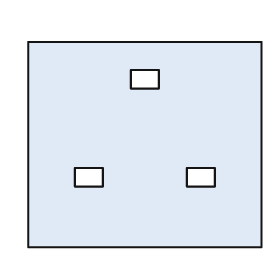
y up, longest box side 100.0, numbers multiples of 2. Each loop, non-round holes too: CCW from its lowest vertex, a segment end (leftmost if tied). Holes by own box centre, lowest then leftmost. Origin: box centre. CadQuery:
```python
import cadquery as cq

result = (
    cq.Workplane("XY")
    .moveTo(-50.0, -44.0)
    .lineTo(50.0, -44.0)
    .lineTo(50.0, 44.0)
    .lineTo(-50.0, 44.0)
    .close()
    .moveTo(-30.0, -18.0)
    .lineTo(-18.0, -18.0)
    .lineTo(-18.0, -10.0)
    .lineTo(-30.0, -10.0)
    .close()
    .moveTo(18.0, -18.0)
    .lineTo(30.0, -18.0)
    .lineTo(30.0, -10.0)
    .lineTo(18.0, -10.0)
    .close()
    .moveTo(-6.0, 24.0)
    .lineTo(6.0, 24.0)
    .lineTo(6.0, 32.0)
    .lineTo(-6.0, 32.0)
    .close()
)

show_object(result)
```